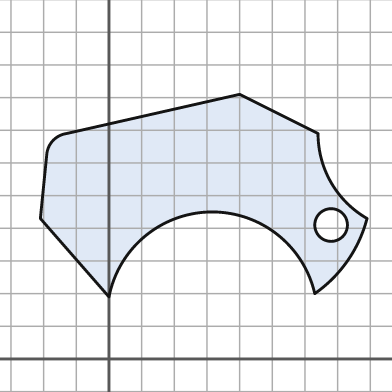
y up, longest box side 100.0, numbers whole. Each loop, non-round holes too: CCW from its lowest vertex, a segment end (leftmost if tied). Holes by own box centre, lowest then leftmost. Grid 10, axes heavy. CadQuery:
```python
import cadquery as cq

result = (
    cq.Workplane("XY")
    .moveTo(0.0, 19.0)
    .threePointArc((31.0, 45.0), (63.0, 20.0))
    .threePointArc((73.0, 30.0), (79.0, 43.0))
    .threePointArc((68.0, 54.0), (64.0, 69.0))
    .lineTo(40.0, 81.0)
    .lineTo(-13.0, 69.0)
    .threePointArc((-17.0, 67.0), (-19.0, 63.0))
    .lineTo(-21.0, 43.0)
    .close()
    .moveTo(68.0, 41.0)
    .circle(5.0)
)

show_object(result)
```